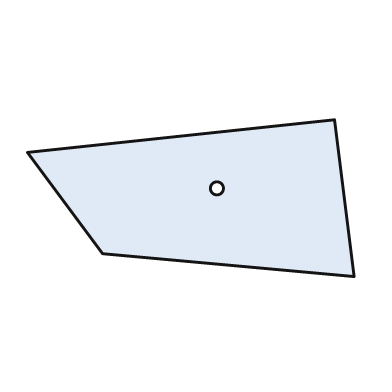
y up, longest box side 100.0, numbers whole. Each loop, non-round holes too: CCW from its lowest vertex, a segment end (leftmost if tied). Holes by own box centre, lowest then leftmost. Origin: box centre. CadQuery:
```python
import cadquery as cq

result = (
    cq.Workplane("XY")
    .moveTo(50.0, -24.0)
    .lineTo(44.0, 24.0)
    .lineTo(-50.0, 14.0)
    .lineTo(-27.0, -17.0)
    .close()
    .moveTo(8.0, 3.0)
    .circle(2.0)
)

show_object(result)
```